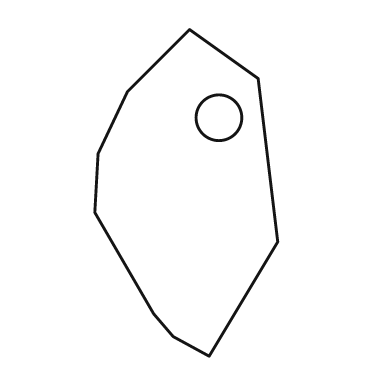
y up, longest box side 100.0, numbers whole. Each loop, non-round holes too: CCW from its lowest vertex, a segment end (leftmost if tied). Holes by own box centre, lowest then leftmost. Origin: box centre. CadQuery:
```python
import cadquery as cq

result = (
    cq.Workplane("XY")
    .moveTo(7.0, -50.0)
    .lineTo(28.0, -15.0)
    .lineTo(22.0, 35.0)
    .lineTo(1.0, 50.0)
    .lineTo(-18.0, 31.0)
    .lineTo(-27.0, 12.0)
    .lineTo(-28.0, -6.0)
    .lineTo(-10.0, -37.0)
    .lineTo(-4.0, -44.0)
    .close()
    .moveTo(10.0, 23.0)
    .circle(7.0)
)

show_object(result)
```